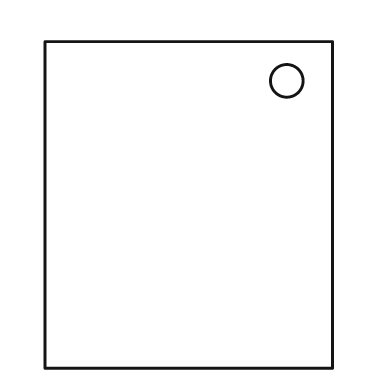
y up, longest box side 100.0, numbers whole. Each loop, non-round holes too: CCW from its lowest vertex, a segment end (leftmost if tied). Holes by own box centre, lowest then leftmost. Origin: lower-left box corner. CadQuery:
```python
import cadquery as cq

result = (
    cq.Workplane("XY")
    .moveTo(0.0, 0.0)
    .lineTo(88.0, 0.0)
    .lineTo(88.0, 100.0)
    .lineTo(0.0, 100.0)
    .close()
    .moveTo(74.0, 88.0)
    .circle(5.0)
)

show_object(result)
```